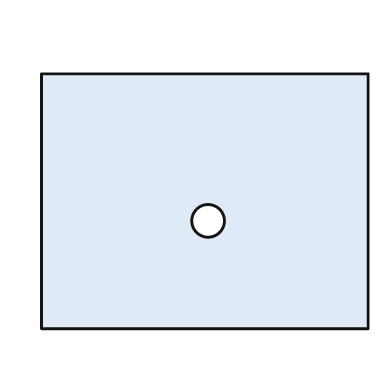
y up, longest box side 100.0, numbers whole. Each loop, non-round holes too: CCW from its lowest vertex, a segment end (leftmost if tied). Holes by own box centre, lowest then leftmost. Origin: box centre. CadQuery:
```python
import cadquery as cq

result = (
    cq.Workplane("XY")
    .moveTo(-50.0, -39.0)
    .lineTo(50.0, -39.0)
    .lineTo(50.0, 39.0)
    .lineTo(-50.0, 39.0)
    .close()
    .moveTo(1.0, -6.0)
    .circle(5.0)
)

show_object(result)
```